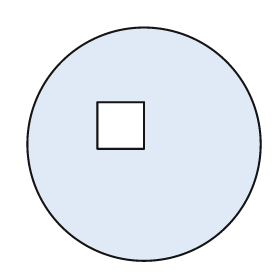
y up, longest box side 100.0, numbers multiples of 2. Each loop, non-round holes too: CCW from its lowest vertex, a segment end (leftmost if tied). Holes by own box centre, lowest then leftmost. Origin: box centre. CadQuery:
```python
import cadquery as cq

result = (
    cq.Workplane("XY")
    .moveTo(0.0, 0.0)
    .circle(50.0)
    .moveTo(-20.0, -2.0)
    .lineTo(0.0, -2.0)
    .lineTo(0.0, 18.0)
    .lineTo(-20.0, 18.0)
    .close()
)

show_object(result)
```